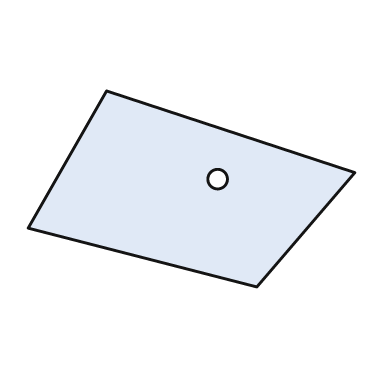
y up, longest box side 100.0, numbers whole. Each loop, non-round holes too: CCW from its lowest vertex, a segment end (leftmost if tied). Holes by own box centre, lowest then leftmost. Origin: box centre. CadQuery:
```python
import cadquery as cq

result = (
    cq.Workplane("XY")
    .moveTo(20.0, -30.0)
    .lineTo(50.0, 5.0)
    .lineTo(-26.0, 30.0)
    .lineTo(-50.0, -12.0)
    .close()
    .moveTo(8.0, 3.0)
    .circle(3.0)
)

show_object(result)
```